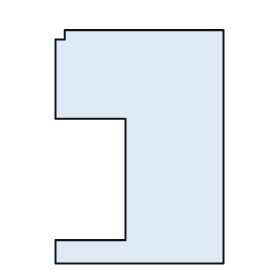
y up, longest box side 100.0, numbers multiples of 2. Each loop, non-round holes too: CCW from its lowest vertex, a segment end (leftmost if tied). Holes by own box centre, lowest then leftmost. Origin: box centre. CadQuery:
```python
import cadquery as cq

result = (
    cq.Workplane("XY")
    .moveTo(-36.0, -50.0)
    .lineTo(36.0, -50.0)
    .lineTo(36.0, 50.0)
    .lineTo(-32.0, 50.0)
    .lineTo(-32.0, 46.0)
    .lineTo(-36.0, 46.0)
    .lineTo(-36.0, 12.0)
    .lineTo(-6.0, 12.0)
    .lineTo(-6.0, -40.0)
    .lineTo(-36.0, -40.0)
    .close()
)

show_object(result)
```